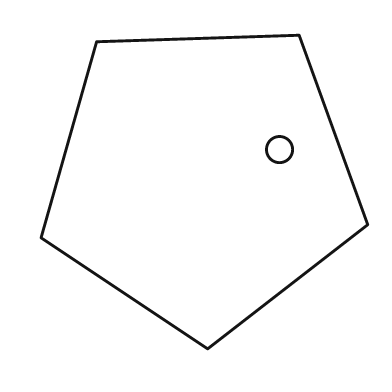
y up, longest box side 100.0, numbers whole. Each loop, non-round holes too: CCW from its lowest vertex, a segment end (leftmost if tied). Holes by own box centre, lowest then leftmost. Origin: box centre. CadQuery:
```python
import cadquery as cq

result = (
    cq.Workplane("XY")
    .moveTo(1.0, -48.0)
    .lineTo(50.0, -10.0)
    .lineTo(29.0, 48.0)
    .lineTo(-33.0, 46.0)
    .lineTo(-50.0, -14.0)
    .close()
    .moveTo(23.0, 13.0)
    .circle(4.0)
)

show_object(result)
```